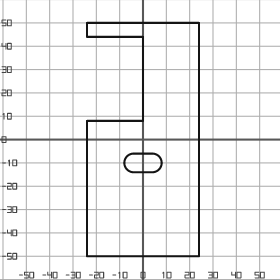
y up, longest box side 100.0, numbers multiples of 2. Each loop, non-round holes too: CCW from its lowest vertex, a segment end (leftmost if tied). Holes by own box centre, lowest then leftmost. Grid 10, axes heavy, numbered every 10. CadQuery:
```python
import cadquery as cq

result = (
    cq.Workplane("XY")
    .moveTo(-24.0, -50.0)
    .lineTo(24.0, -50.0)
    .lineTo(24.0, 50.0)
    .lineTo(-24.0, 50.0)
    .lineTo(-24.0, 44.0)
    .lineTo(0.0, 44.0)
    .lineTo(0.0, 8.0)
    .lineTo(-24.0, 8.0)
    .close()
    .moveTo(-4.0, -14.0)
    .lineTo(4.0, -14.0)
    .threePointArc((8.0, -10.0), (4.0, -6.0))
    .lineTo(-4.0, -6.0)
    .threePointArc((-8.0, -10.0), (-4.0, -14.0))
    .close()
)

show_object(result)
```